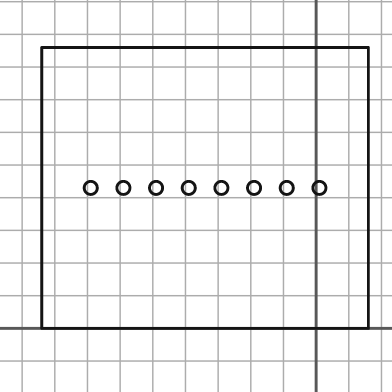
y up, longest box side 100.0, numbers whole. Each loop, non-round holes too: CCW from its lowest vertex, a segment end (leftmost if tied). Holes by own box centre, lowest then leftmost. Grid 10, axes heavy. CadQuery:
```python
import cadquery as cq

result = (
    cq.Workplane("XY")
    .moveTo(-84.0, 0.0)
    .lineTo(16.0, 0.0)
    .lineTo(16.0, 86.0)
    .lineTo(-84.0, 86.0)
    .close()
    .moveTo(-69.0, 43.0)
    .circle(2.0)
    .moveTo(-59.0, 43.0)
    .circle(2.0)
    .moveTo(-49.0, 43.0)
    .circle(2.0)
    .moveTo(-39.0, 43.0)
    .circle(2.0)
    .moveTo(-29.0, 43.0)
    .circle(2.0)
    .moveTo(-19.0, 43.0)
    .circle(2.0)
    .moveTo(-9.0, 43.0)
    .circle(2.0)
    .moveTo(1.0, 43.0)
    .circle(2.0)
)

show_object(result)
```